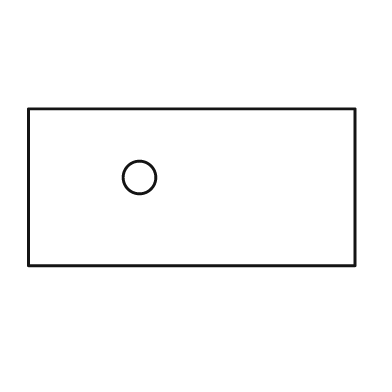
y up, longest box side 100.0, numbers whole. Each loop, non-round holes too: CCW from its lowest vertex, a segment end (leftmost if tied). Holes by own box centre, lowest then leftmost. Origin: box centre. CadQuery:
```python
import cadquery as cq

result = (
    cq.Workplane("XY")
    .moveTo(-50.0, -24.0)
    .lineTo(50.0, -24.0)
    .lineTo(50.0, 24.0)
    .lineTo(-50.0, 24.0)
    .close()
    .moveTo(-16.0, 3.0)
    .circle(5.0)
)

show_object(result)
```